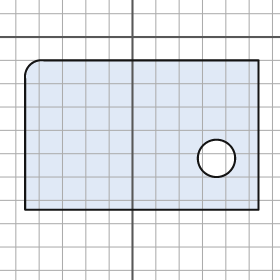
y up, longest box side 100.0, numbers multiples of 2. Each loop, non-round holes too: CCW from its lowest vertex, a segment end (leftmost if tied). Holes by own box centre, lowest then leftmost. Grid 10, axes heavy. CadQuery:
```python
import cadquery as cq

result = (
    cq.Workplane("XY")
    .moveTo(-46.0, -74.0)
    .lineTo(54.0, -74.0)
    .lineTo(54.0, -10.0)
    .lineTo(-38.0, -10.0)
    .threePointArc((-44.0, -12.0), (-46.0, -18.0))
    .close()
    .moveTo(36.0, -52.0)
    .circle(8.0)
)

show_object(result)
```